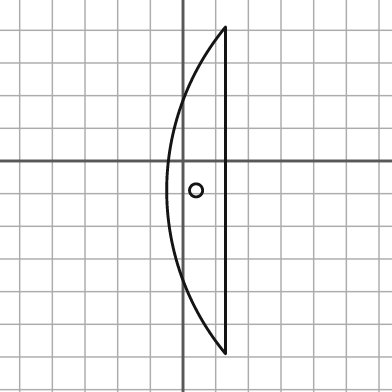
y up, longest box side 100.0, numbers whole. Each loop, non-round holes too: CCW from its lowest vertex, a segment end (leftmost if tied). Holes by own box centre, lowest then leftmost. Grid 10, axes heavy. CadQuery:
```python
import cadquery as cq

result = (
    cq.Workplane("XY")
    .moveTo(13.0, -59.0)
    .lineTo(13.0, 41.0)
    .threePointArc((-5.0, -9.0), (13.0, -59.0))
    .close()
    .moveTo(4.0, -9.0)
    .circle(2.0)
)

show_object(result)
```